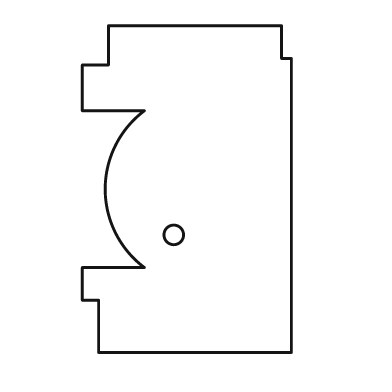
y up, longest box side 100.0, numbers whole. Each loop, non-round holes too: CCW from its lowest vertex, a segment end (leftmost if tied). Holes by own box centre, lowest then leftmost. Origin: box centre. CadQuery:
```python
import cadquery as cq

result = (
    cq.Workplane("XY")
    .moveTo(-27.0, -50.0)
    .lineTo(32.0, -50.0)
    .lineTo(32.0, 40.0)
    .lineTo(29.0, 40.0)
    .lineTo(29.0, 50.0)
    .lineTo(-24.0, 50.0)
    .lineTo(-24.0, 38.0)
    .lineTo(-32.0, 38.0)
    .lineTo(-32.0, 24.0)
    .lineTo(-13.0, 24.0)
    .threePointArc((-25.0, 0.0), (-13.0, -24.0))
    .lineTo(-32.0, -24.0)
    .lineTo(-32.0, -34.0)
    .lineTo(-27.0, -34.0)
    .close()
    .moveTo(-4.0, -14.0)
    .circle(3.0)
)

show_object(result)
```